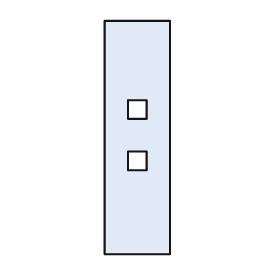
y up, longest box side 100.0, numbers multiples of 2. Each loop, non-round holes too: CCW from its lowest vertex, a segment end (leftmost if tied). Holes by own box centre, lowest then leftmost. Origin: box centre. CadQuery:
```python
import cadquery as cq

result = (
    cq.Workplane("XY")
    .moveTo(-14.0, -50.0)
    .lineTo(14.0, -50.0)
    .lineTo(14.0, 50.0)
    .lineTo(-14.0, 50.0)
    .close()
    .moveTo(-4.0, -14.0)
    .lineTo(4.0, -14.0)
    .lineTo(4.0, -6.0)
    .lineTo(-4.0, -6.0)
    .close()
    .moveTo(-4.0, 8.0)
    .lineTo(4.0, 8.0)
    .lineTo(4.0, 16.0)
    .lineTo(-4.0, 16.0)
    .close()
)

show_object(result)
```